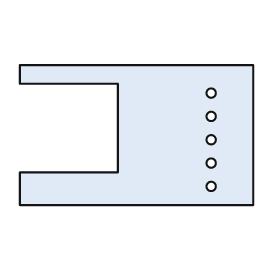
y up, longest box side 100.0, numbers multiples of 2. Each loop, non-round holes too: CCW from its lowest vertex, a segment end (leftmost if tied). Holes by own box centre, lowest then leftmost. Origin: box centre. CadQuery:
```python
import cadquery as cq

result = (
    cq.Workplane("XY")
    .moveTo(-50.0, -30.0)
    .lineTo(50.0, -30.0)
    .lineTo(50.0, 30.0)
    .lineTo(-50.0, 30.0)
    .lineTo(-50.0, 22.0)
    .lineTo(-8.0, 22.0)
    .lineTo(-8.0, -16.0)
    .lineTo(-50.0, -16.0)
    .close()
    .moveTo(32.0, -22.0)
    .circle(2.0)
    .moveTo(32.0, -12.0)
    .circle(2.0)
    .moveTo(32.0, -2.0)
    .circle(2.0)
    .moveTo(32.0, 8.0)
    .circle(2.0)
    .moveTo(32.0, 18.0)
    .circle(2.0)
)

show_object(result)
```